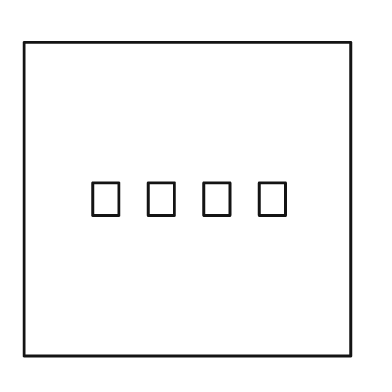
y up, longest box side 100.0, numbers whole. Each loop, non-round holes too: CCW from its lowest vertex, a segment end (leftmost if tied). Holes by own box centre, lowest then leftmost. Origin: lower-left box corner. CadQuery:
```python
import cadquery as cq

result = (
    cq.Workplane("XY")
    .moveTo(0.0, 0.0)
    .lineTo(100.0, 0.0)
    .lineTo(100.0, 96.0)
    .lineTo(0.0, 96.0)
    .close()
    .moveTo(21.0, 43.0)
    .lineTo(29.0, 43.0)
    .lineTo(29.0, 53.0)
    .lineTo(21.0, 53.0)
    .close()
    .moveTo(38.0, 43.0)
    .lineTo(46.0, 43.0)
    .lineTo(46.0, 53.0)
    .lineTo(38.0, 53.0)
    .close()
    .moveTo(55.0, 43.0)
    .lineTo(63.0, 43.0)
    .lineTo(63.0, 53.0)
    .lineTo(55.0, 53.0)
    .close()
    .moveTo(72.0, 43.0)
    .lineTo(80.0, 43.0)
    .lineTo(80.0, 53.0)
    .lineTo(72.0, 53.0)
    .close()
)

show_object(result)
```